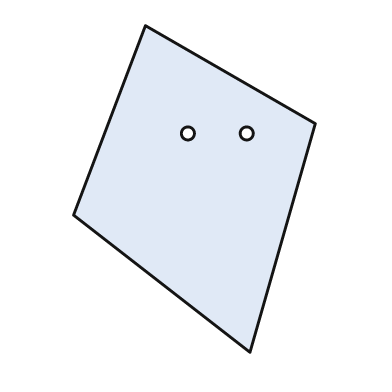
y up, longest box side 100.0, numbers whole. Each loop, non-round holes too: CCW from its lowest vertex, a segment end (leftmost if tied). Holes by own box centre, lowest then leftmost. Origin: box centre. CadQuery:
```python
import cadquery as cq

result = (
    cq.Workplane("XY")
    .moveTo(17.0, -50.0)
    .lineTo(37.0, 20.0)
    .lineTo(-15.0, 50.0)
    .lineTo(-37.0, -8.0)
    .close()
    .moveTo(-2.0, 17.0)
    .circle(2.0)
    .moveTo(16.0, 17.0)
    .circle(2.0)
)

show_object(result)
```